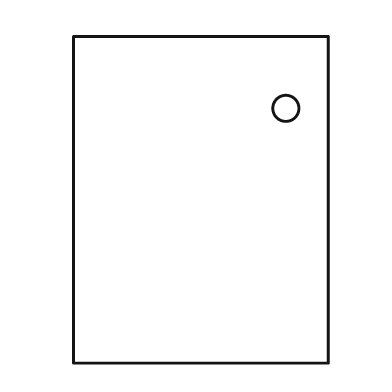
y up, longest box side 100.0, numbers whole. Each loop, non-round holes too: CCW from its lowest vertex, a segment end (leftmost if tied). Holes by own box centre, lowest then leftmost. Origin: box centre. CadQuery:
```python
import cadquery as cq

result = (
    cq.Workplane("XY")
    .moveTo(-39.0, -50.0)
    .lineTo(39.0, -50.0)
    .lineTo(39.0, 50.0)
    .lineTo(-39.0, 50.0)
    .close()
    .moveTo(26.0, 28.0)
    .circle(4.0)
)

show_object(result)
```